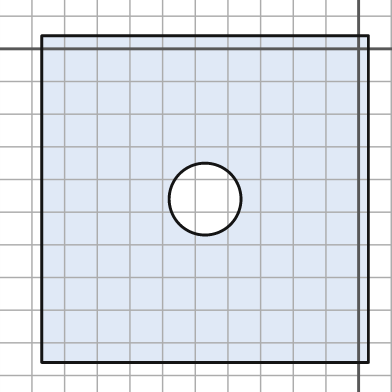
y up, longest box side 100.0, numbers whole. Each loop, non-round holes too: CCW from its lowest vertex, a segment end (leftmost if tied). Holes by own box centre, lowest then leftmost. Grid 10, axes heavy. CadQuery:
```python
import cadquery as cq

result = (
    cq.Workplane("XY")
    .moveTo(-97.0, -96.0)
    .lineTo(3.0, -96.0)
    .lineTo(3.0, 4.0)
    .lineTo(-97.0, 4.0)
    .close()
    .moveTo(-47.0, -46.0)
    .circle(11.0)
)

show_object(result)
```